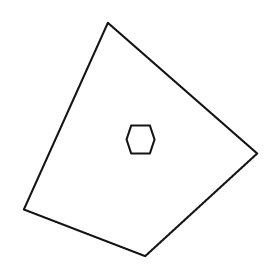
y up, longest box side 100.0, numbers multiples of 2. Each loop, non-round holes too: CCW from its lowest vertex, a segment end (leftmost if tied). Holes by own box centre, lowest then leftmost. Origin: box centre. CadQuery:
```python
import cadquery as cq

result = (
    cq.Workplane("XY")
    .moveTo(2.0, -50.0)
    .lineTo(50.0, -6.0)
    .lineTo(-14.0, 50.0)
    .lineTo(-50.0, -30.0)
    .close()
    .moveTo(-4.0, -6.0)
    .lineTo(4.0, -6.0)
    .lineTo(6.0, 0.0)
    .lineTo(4.0, 6.0)
    .lineTo(-4.0, 6.0)
    .lineTo(-6.0, 0.0)
    .close()
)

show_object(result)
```